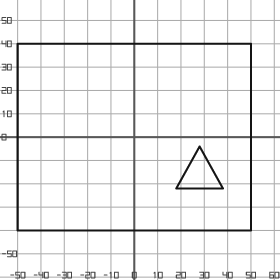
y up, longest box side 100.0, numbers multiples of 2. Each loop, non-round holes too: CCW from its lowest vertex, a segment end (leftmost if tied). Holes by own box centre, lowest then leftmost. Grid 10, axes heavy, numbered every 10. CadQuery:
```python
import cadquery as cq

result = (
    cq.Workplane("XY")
    .moveTo(-50.0, -40.0)
    .lineTo(50.0, -40.0)
    .lineTo(50.0, 40.0)
    .lineTo(-50.0, 40.0)
    .close()
    .moveTo(18.0, -22.0)
    .lineTo(38.0, -22.0)
    .lineTo(28.0, -4.0)
    .close()
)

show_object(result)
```